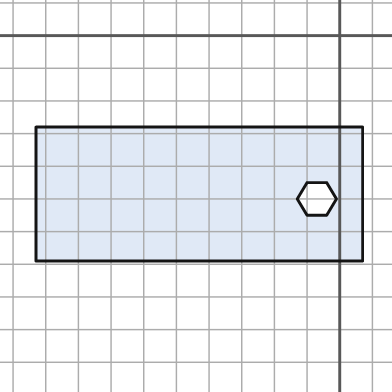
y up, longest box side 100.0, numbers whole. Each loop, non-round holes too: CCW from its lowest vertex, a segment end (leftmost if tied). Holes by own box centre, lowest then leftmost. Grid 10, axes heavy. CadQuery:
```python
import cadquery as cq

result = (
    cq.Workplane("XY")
    .moveTo(-93.0, -69.0)
    .lineTo(7.0, -69.0)
    .lineTo(7.0, -28.0)
    .lineTo(-93.0, -28.0)
    .close()
    .moveTo(-10.0, -55.0)
    .lineTo(-4.0, -55.0)
    .lineTo(-1.0, -50.0)
    .lineTo(-4.0, -45.0)
    .lineTo(-10.0, -45.0)
    .lineTo(-13.0, -50.0)
    .close()
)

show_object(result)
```